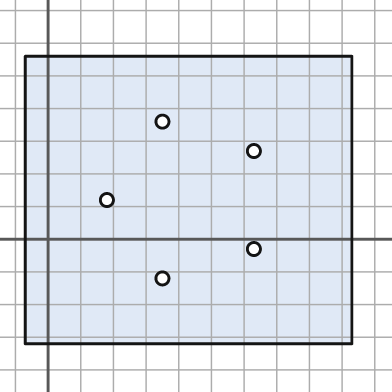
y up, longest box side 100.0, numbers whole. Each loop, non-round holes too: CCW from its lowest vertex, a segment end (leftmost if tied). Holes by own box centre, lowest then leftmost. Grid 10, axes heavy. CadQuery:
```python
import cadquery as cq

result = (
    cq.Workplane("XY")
    .moveTo(-7.0, -32.0)
    .lineTo(93.0, -32.0)
    .lineTo(93.0, 56.0)
    .lineTo(-7.0, 56.0)
    .close()
    .moveTo(35.0, -12.0)
    .circle(2.0)
    .moveTo(63.0, -3.0)
    .circle(2.0)
    .moveTo(18.0, 12.0)
    .circle(2.0)
    .moveTo(63.0, 27.0)
    .circle(2.0)
    .moveTo(35.0, 36.0)
    .circle(2.0)
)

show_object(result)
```